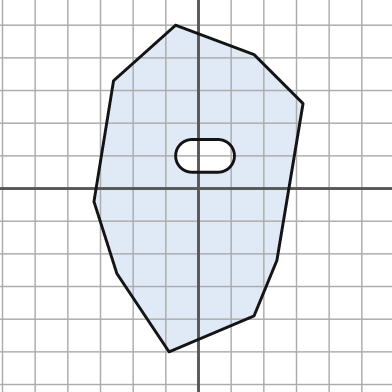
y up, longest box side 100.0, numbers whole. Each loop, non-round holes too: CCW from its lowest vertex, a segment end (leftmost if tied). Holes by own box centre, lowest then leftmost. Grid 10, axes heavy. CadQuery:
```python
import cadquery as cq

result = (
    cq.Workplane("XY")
    .moveTo(-9.0, -50.0)
    .lineTo(17.0, -39.0)
    .lineTo(24.0, -22.0)
    .lineTo(32.0, 26.0)
    .lineTo(17.0, 41.0)
    .lineTo(-7.0, 50.0)
    .lineTo(-26.0, 33.0)
    .lineTo(-32.0, -4.0)
    .lineTo(-25.0, -26.0)
    .close()
    .moveTo(-2.0, 5.0)
    .lineTo(6.0, 5.0)
    .threePointArc((11.0, 10.0), (6.0, 15.0))
    .lineTo(-2.0, 15.0)
    .threePointArc((-7.0, 10.0), (-2.0, 5.0))
    .close()
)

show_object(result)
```